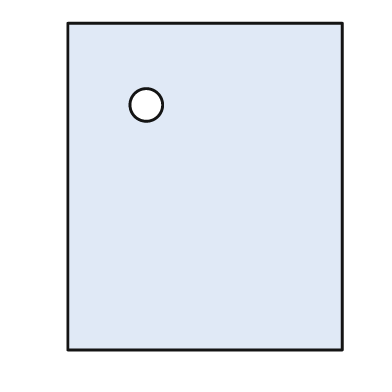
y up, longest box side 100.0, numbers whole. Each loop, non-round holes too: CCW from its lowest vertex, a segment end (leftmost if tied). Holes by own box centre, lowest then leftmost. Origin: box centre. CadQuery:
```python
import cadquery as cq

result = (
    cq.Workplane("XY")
    .moveTo(-42.0, -50.0)
    .lineTo(42.0, -50.0)
    .lineTo(42.0, 50.0)
    .lineTo(-42.0, 50.0)
    .close()
    .moveTo(-18.0, 25.0)
    .circle(5.0)
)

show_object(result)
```